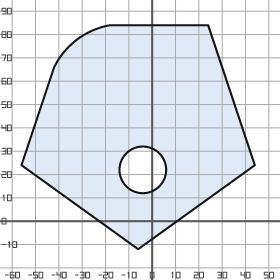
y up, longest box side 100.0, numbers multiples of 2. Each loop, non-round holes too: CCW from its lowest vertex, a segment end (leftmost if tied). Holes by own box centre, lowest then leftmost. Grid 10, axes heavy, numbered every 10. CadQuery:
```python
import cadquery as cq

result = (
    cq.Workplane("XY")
    .moveTo(-6.0, -12.0)
    .lineTo(44.0, 24.0)
    .lineTo(24.0, 84.0)
    .lineTo(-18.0, 84.0)
    .threePointArc((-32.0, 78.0), (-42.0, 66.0))
    .lineTo(-56.0, 24.0)
    .close()
    .moveTo(-4.0, 22.0)
    .circle(10.0)
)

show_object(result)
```